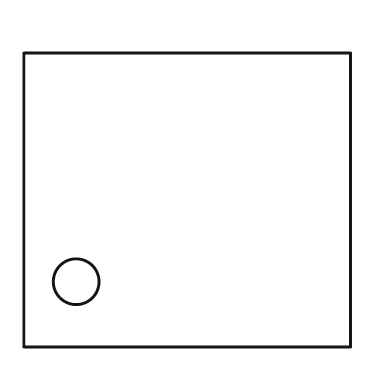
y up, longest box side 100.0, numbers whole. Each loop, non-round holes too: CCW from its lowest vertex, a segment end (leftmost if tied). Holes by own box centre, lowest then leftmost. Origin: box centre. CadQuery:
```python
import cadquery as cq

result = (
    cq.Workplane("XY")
    .moveTo(-50.0, -45.0)
    .lineTo(50.0, -45.0)
    .lineTo(50.0, 45.0)
    .lineTo(-50.0, 45.0)
    .close()
    .moveTo(-34.0, -25.0)
    .circle(7.0)
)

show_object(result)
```